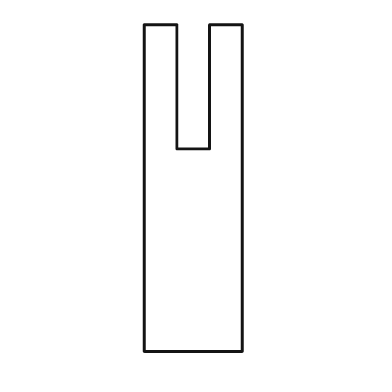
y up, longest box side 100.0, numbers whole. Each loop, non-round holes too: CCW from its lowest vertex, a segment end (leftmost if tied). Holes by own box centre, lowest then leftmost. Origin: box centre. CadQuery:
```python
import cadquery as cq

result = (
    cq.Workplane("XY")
    .moveTo(-15.0, -50.0)
    .lineTo(15.0, -50.0)
    .lineTo(15.0, 50.0)
    .lineTo(5.0, 50.0)
    .lineTo(5.0, 12.0)
    .lineTo(-5.0, 12.0)
    .lineTo(-5.0, 50.0)
    .lineTo(-15.0, 50.0)
    .close()
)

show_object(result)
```